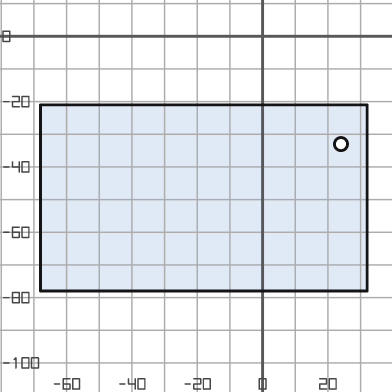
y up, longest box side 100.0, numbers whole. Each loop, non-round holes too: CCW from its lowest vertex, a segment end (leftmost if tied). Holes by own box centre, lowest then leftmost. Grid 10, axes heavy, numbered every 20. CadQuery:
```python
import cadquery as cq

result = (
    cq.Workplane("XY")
    .moveTo(-68.0, -78.0)
    .lineTo(32.0, -78.0)
    .lineTo(32.0, -21.0)
    .lineTo(-68.0, -21.0)
    .close()
    .moveTo(24.0, -33.0)
    .circle(2.0)
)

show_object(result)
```